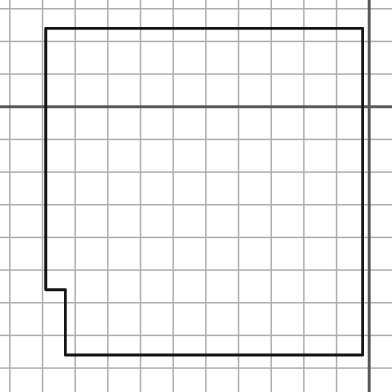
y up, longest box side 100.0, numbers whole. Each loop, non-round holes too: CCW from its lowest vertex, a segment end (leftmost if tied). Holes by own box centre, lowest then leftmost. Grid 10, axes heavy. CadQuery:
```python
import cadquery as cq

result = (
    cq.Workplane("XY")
    .moveTo(-93.0, -76.0)
    .lineTo(-2.0, -76.0)
    .lineTo(-2.0, 24.0)
    .lineTo(-99.0, 24.0)
    .lineTo(-99.0, -56.0)
    .lineTo(-93.0, -56.0)
    .close()
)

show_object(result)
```